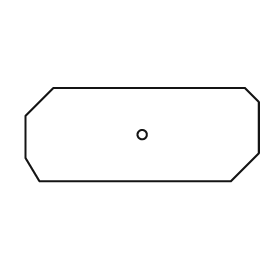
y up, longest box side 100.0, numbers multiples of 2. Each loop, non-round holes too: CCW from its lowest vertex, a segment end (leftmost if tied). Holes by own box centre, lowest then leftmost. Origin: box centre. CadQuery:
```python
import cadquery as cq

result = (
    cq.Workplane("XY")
    .moveTo(-44.0, -20.0)
    .lineTo(38.0, -20.0)
    .lineTo(50.0, -8.0)
    .lineTo(50.0, 14.0)
    .lineTo(44.0, 20.0)
    .lineTo(-38.0, 20.0)
    .lineTo(-50.0, 8.0)
    .lineTo(-50.0, -10.0)
    .close()
    .moveTo(0.0, 0.0)
    .circle(2.0)
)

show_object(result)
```